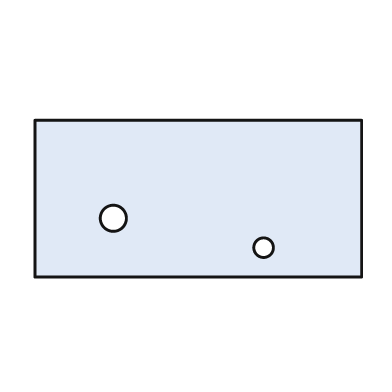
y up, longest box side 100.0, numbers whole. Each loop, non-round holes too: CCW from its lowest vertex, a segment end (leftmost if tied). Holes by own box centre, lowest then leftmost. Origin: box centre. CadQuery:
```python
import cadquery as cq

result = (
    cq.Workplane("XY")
    .moveTo(-50.0, -24.0)
    .lineTo(50.0, -24.0)
    .lineTo(50.0, 24.0)
    .lineTo(-50.0, 24.0)
    .close()
    .moveTo(20.0, -15.0)
    .circle(3.0)
    .moveTo(-26.0, -6.0)
    .circle(4.0)
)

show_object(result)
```